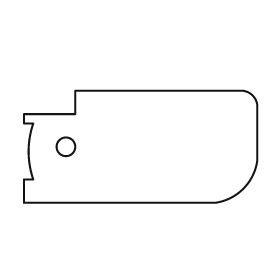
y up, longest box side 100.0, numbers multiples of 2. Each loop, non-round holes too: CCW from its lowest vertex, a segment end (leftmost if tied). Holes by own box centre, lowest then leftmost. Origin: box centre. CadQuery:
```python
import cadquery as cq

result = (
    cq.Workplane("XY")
    .moveTo(-50.0, -24.0)
    .lineTo(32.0, -24.0)
    .threePointArc((44.0, -18.0), (50.0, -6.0))
    .lineTo(50.0, 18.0)
    .threePointArc((48.0, 22.0), (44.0, 24.0))
    .lineTo(-28.0, 24.0)
    .lineTo(-28.0, 14.0)
    .lineTo(-50.0, 14.0)
    .lineTo(-50.0, 10.0)
    .lineTo(-46.0, 10.0)
    .threePointArc((-48.0, -2.0), (-46.0, -14.0))
    .lineTo(-50.0, -14.0)
    .close()
    .moveTo(-32.0, 0.0)
    .circle(4.0)
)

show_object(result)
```